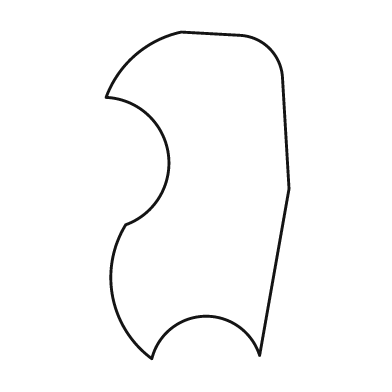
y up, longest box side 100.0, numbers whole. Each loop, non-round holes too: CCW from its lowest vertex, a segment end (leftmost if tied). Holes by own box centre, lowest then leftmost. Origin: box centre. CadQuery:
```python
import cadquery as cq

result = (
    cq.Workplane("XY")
    .moveTo(-14.0, -50.0)
    .threePointArc((2.0, -37.0), (19.0, -49.0))
    .lineTo(28.0, 2.0)
    .lineTo(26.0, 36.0)
    .threePointArc((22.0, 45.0), (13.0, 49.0))
    .lineTo(-5.0, 50.0)
    .threePointArc((-19.0, 43.0), (-28.0, 30.0))
    .threePointArc((-9.0, 13.0), (-22.0, -9.0))
    .threePointArc((-26.0, -31.0), (-14.0, -50.0))
    .close()
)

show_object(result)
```